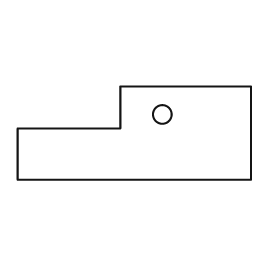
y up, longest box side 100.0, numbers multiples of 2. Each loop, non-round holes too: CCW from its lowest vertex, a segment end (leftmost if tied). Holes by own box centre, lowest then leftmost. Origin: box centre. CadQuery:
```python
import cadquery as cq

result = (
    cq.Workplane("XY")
    .moveTo(-50.0, -20.0)
    .lineTo(50.0, -20.0)
    .lineTo(50.0, 20.0)
    .lineTo(-6.0, 20.0)
    .lineTo(-6.0, 2.0)
    .lineTo(-50.0, 2.0)
    .close()
    .moveTo(12.0, 8.0)
    .circle(4.0)
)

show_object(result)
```